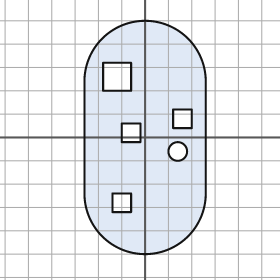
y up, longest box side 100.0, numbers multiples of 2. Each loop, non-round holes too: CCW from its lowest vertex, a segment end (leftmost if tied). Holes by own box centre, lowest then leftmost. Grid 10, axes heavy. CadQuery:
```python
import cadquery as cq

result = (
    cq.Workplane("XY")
    .moveTo(-26.0, -24.0)
    .threePointArc((0.0, -50.0), (26.0, -24.0))
    .lineTo(26.0, 24.0)
    .threePointArc((0.0, 50.0), (-26.0, 24.0))
    .close()
    .moveTo(-14.0, -32.0)
    .lineTo(-6.0, -32.0)
    .lineTo(-6.0, -24.0)
    .lineTo(-14.0, -24.0)
    .close()
    .moveTo(14.0, -6.0)
    .circle(4.0)
    .moveTo(-10.0, -2.0)
    .lineTo(-2.0, -2.0)
    .lineTo(-2.0, 6.0)
    .lineTo(-10.0, 6.0)
    .close()
    .moveTo(12.0, 4.0)
    .lineTo(20.0, 4.0)
    .lineTo(20.0, 12.0)
    .lineTo(12.0, 12.0)
    .close()
    .moveTo(-18.0, 20.0)
    .lineTo(-6.0, 20.0)
    .lineTo(-6.0, 32.0)
    .lineTo(-18.0, 32.0)
    .close()
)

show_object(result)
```